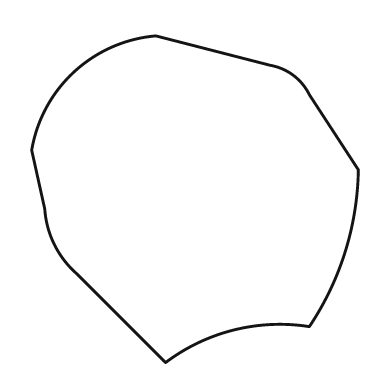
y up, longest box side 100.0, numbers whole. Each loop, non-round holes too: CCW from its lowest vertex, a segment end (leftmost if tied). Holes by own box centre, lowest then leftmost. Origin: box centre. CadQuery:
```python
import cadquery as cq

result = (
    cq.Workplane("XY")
    .moveTo(-9.0, -50.0)
    .threePointArc((12.0, -40.0), (35.0, -39.0))
    .threePointArc((46.0, -16.0), (50.0, 9.0))
    .lineTo(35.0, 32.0)
    .threePointArc((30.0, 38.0), (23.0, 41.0))
    .lineTo(-12.0, 50.0)
    .threePointArc((-37.0, 39.0), (-50.0, 15.0))
    .lineTo(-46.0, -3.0)
    .threePointArc((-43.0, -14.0), (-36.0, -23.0))
    .close()
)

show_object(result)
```